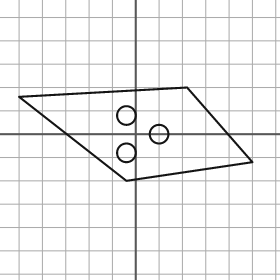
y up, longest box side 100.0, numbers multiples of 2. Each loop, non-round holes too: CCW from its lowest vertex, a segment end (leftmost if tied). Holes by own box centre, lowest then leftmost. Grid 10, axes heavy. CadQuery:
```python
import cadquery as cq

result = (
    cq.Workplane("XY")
    .moveTo(-4.0, -20.0)
    .lineTo(50.0, -12.0)
    .lineTo(22.0, 20.0)
    .lineTo(-50.0, 16.0)
    .close()
    .moveTo(-4.0, -8.0)
    .circle(4.0)
    .moveTo(10.0, 0.0)
    .circle(4.0)
    .moveTo(-4.0, 8.0)
    .circle(4.0)
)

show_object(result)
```